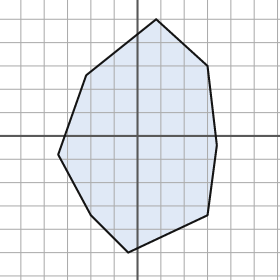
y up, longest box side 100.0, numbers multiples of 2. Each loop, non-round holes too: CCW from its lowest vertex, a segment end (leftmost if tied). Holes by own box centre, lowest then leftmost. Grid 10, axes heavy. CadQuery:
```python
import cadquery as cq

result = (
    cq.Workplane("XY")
    .moveTo(-4.0, -50.0)
    .lineTo(30.0, -34.0)
    .lineTo(34.0, -4.0)
    .lineTo(30.0, 30.0)
    .lineTo(8.0, 50.0)
    .lineTo(-22.0, 26.0)
    .lineTo(-34.0, -8.0)
    .lineTo(-20.0, -34.0)
    .close()
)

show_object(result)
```